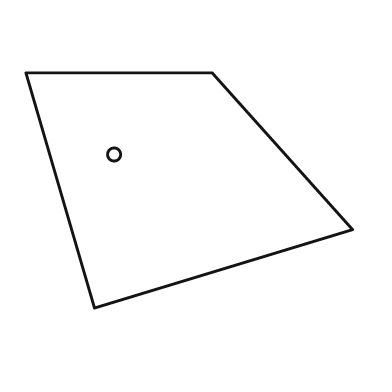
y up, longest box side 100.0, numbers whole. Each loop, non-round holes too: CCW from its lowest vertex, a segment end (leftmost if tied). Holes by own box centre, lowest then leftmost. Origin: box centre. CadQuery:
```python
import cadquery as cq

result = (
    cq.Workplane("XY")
    .moveTo(-29.0, -36.0)
    .lineTo(50.0, -12.0)
    .lineTo(7.0, 36.0)
    .lineTo(-50.0, 36.0)
    .close()
    .moveTo(-23.0, 11.0)
    .circle(2.0)
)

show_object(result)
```